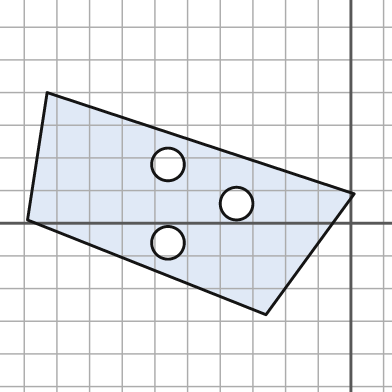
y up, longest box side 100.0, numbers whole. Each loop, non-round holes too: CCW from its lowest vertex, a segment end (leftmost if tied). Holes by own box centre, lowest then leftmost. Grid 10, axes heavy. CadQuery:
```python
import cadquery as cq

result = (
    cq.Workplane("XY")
    .moveTo(-26.0, -28.0)
    .lineTo(1.0, 9.0)
    .lineTo(-93.0, 40.0)
    .lineTo(-99.0, 1.0)
    .close()
    .moveTo(-56.0, -6.0)
    .circle(5.0)
    .moveTo(-35.0, 6.0)
    .circle(5.0)
    .moveTo(-56.0, 18.0)
    .circle(5.0)
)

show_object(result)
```